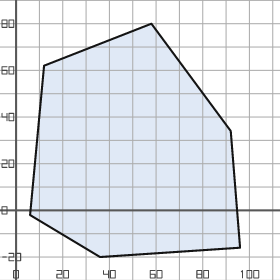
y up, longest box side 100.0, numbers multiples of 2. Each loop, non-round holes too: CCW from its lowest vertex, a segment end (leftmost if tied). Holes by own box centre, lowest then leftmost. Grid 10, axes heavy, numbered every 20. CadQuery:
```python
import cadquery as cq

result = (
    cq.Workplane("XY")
    .moveTo(36.0, -20.0)
    .lineTo(96.0, -16.0)
    .lineTo(92.0, 34.0)
    .lineTo(58.0, 80.0)
    .lineTo(12.0, 62.0)
    .lineTo(6.0, -2.0)
    .close()
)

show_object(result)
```